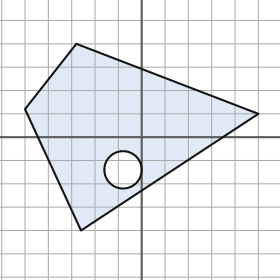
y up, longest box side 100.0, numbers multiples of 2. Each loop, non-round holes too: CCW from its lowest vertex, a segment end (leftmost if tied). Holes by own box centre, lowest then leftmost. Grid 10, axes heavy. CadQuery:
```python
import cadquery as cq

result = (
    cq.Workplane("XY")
    .moveTo(-26.0, -40.0)
    .lineTo(50.0, 10.0)
    .lineTo(-28.0, 40.0)
    .lineTo(-50.0, 12.0)
    .close()
    .moveTo(-8.0, -14.0)
    .circle(8.0)
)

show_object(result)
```